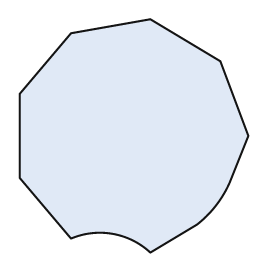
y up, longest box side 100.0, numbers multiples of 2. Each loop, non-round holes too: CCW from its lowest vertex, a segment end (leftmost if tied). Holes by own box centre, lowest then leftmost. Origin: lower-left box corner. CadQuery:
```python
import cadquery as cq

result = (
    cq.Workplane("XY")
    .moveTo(56.0, 0.0)
    .lineTo(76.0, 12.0)
    .threePointArc((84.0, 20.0), (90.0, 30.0))
    .lineTo(98.0, 50.0)
    .lineTo(86.0, 82.0)
    .lineTo(56.0, 100.0)
    .lineTo(22.0, 94.0)
    .lineTo(0.0, 68.0)
    .lineTo(0.0, 32.0)
    .lineTo(22.0, 6.0)
    .threePointArc((40.0, 8.0), (56.0, 0.0))
    .close()
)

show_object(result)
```